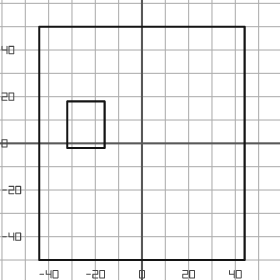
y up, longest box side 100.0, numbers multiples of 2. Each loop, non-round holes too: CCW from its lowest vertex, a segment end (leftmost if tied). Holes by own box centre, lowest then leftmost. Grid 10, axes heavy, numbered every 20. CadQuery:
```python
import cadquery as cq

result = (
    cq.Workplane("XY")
    .moveTo(-44.0, -50.0)
    .lineTo(44.0, -50.0)
    .lineTo(44.0, 50.0)
    .lineTo(-44.0, 50.0)
    .close()
    .moveTo(-32.0, -2.0)
    .lineTo(-16.0, -2.0)
    .lineTo(-16.0, 18.0)
    .lineTo(-32.0, 18.0)
    .close()
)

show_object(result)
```